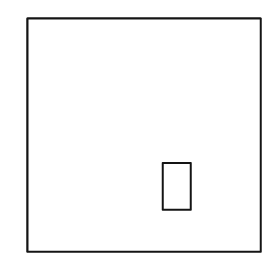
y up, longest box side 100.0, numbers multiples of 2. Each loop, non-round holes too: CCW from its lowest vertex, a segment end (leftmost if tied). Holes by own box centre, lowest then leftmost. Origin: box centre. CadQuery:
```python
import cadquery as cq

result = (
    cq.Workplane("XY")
    .moveTo(-50.0, -50.0)
    .lineTo(50.0, -50.0)
    .lineTo(50.0, 50.0)
    .lineTo(-50.0, 50.0)
    .close()
    .moveTo(8.0, -32.0)
    .lineTo(20.0, -32.0)
    .lineTo(20.0, -12.0)
    .lineTo(8.0, -12.0)
    .close()
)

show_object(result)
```